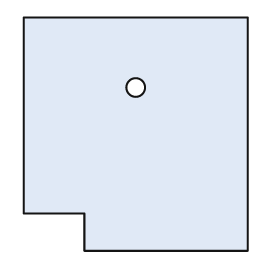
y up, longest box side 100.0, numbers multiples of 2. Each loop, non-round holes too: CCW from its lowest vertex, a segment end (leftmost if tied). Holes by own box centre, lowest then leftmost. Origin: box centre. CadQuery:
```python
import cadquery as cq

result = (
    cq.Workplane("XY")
    .moveTo(-22.0, -50.0)
    .lineTo(48.0, -50.0)
    .lineTo(48.0, 50.0)
    .lineTo(-48.0, 50.0)
    .lineTo(-48.0, -34.0)
    .lineTo(-22.0, -34.0)
    .close()
    .moveTo(0.0, 20.0)
    .circle(4.0)
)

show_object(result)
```